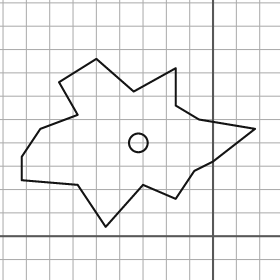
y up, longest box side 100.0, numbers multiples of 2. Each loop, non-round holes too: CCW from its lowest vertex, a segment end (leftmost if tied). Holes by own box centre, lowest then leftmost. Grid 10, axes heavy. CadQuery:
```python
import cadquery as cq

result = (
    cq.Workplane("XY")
    .moveTo(-46.0, 4.0)
    .lineTo(-30.0, 22.0)
    .lineTo(-16.0, 16.0)
    .lineTo(-8.0, 28.0)
    .lineTo(0.0, 32.0)
    .lineTo(18.0, 46.0)
    .lineTo(-6.0, 50.0)
    .lineTo(-16.0, 56.0)
    .lineTo(-16.0, 72.0)
    .lineTo(-34.0, 62.0)
    .lineTo(-50.0, 76.0)
    .lineTo(-66.0, 66.0)
    .lineTo(-58.0, 52.0)
    .lineTo(-74.0, 46.0)
    .lineTo(-82.0, 34.0)
    .lineTo(-82.0, 24.0)
    .lineTo(-58.0, 22.0)
    .close()
    .moveTo(-32.0, 40.0)
    .circle(4.0)
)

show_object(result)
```